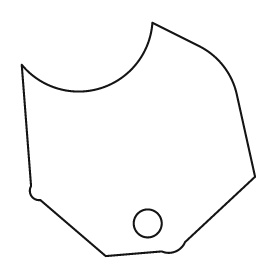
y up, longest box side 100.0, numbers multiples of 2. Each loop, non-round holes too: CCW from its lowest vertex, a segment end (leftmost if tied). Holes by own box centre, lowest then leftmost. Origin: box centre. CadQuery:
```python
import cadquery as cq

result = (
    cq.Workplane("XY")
    .moveTo(-14.0, -50.0)
    .lineTo(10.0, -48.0)
    .threePointArc((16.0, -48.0), (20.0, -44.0))
    .lineTo(50.0, -16.0)
    .lineTo(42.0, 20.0)
    .threePointArc((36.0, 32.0), (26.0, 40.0))
    .lineTo(6.0, 50.0)
    .threePointArc((-16.0, 22.0), (-50.0, 32.0))
    .lineTo(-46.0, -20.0)
    .threePointArc((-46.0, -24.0), (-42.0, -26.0))
    .close()
    .moveTo(4.0, -36.0)
    .circle(6.0)
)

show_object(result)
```